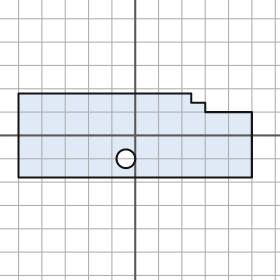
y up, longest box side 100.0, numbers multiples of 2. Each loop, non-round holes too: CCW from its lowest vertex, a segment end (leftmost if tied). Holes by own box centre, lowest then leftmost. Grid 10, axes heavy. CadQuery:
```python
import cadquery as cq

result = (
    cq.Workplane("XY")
    .moveTo(-50.0, -18.0)
    .lineTo(50.0, -18.0)
    .lineTo(50.0, 10.0)
    .lineTo(30.0, 10.0)
    .lineTo(30.0, 14.0)
    .lineTo(24.0, 14.0)
    .lineTo(24.0, 18.0)
    .lineTo(-50.0, 18.0)
    .close()
    .moveTo(-4.0, -10.0)
    .circle(4.0)
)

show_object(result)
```